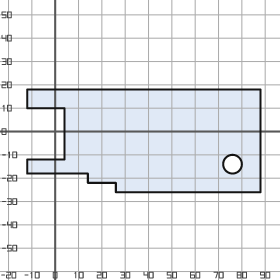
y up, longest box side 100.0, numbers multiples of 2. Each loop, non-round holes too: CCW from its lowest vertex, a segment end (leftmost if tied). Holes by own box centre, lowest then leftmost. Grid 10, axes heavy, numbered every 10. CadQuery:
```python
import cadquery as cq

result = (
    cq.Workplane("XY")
    .moveTo(26.0, -26.0)
    .lineTo(88.0, -26.0)
    .lineTo(88.0, 18.0)
    .lineTo(-12.0, 18.0)
    .lineTo(-12.0, 10.0)
    .lineTo(4.0, 10.0)
    .lineTo(4.0, -12.0)
    .lineTo(-12.0, -12.0)
    .lineTo(-12.0, -18.0)
    .lineTo(14.0, -18.0)
    .lineTo(14.0, -22.0)
    .lineTo(26.0, -22.0)
    .close()
    .moveTo(76.0, -14.0)
    .circle(4.0)
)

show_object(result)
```